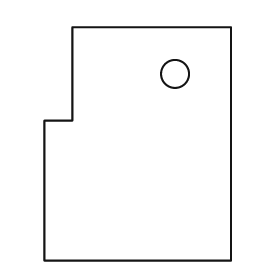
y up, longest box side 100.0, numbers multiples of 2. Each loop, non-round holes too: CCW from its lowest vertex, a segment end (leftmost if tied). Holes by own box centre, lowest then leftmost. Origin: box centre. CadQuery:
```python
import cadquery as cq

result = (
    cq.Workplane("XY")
    .moveTo(-40.0, -50.0)
    .lineTo(40.0, -50.0)
    .lineTo(40.0, 50.0)
    .lineTo(-28.0, 50.0)
    .lineTo(-28.0, 10.0)
    .lineTo(-40.0, 10.0)
    .close()
    .moveTo(16.0, 30.0)
    .circle(6.0)
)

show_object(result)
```